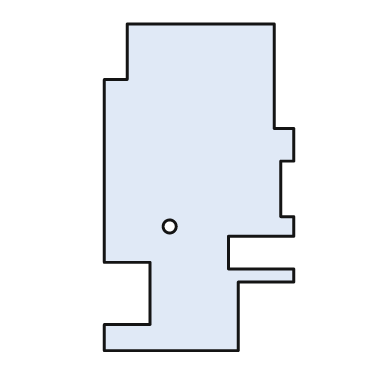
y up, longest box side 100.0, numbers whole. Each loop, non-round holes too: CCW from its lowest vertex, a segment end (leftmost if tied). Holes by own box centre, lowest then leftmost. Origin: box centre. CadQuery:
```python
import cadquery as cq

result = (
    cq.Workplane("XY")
    .moveTo(-29.0, -50.0)
    .lineTo(12.0, -50.0)
    .lineTo(12.0, -29.0)
    .lineTo(29.0, -29.0)
    .lineTo(29.0, -25.0)
    .lineTo(9.0, -25.0)
    .lineTo(9.0, -15.0)
    .lineTo(29.0, -15.0)
    .lineTo(29.0, -9.0)
    .lineTo(25.0, -9.0)
    .lineTo(25.0, 8.0)
    .lineTo(29.0, 8.0)
    .lineTo(29.0, 18.0)
    .lineTo(23.0, 18.0)
    .lineTo(23.0, 50.0)
    .lineTo(-22.0, 50.0)
    .lineTo(-22.0, 33.0)
    .lineTo(-29.0, 33.0)
    .lineTo(-29.0, -23.0)
    .lineTo(-15.0, -23.0)
    .lineTo(-15.0, -42.0)
    .lineTo(-29.0, -42.0)
    .close()
    .moveTo(-9.0, -12.0)
    .circle(2.0)
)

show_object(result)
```